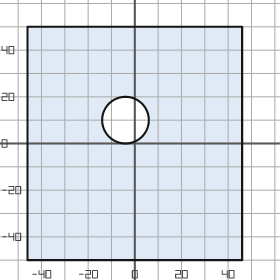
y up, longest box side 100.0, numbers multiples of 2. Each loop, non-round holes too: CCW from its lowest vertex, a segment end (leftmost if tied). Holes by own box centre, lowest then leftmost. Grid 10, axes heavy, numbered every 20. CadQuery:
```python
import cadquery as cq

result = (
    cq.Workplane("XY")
    .moveTo(-46.0, -50.0)
    .lineTo(46.0, -50.0)
    .lineTo(46.0, 50.0)
    .lineTo(-46.0, 50.0)
    .close()
    .moveTo(-4.0, 10.0)
    .circle(10.0)
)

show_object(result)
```